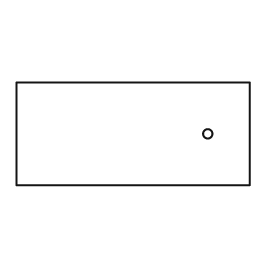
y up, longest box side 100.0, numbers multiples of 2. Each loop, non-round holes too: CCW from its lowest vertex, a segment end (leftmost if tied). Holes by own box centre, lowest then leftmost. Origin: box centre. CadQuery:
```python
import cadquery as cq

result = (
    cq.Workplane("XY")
    .moveTo(-50.0, -22.0)
    .lineTo(50.0, -22.0)
    .lineTo(50.0, 22.0)
    .lineTo(-50.0, 22.0)
    .close()
    .moveTo(32.0, 0.0)
    .circle(2.0)
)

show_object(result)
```